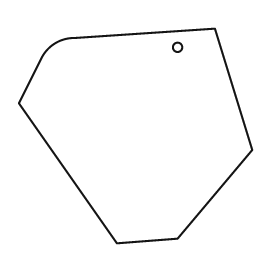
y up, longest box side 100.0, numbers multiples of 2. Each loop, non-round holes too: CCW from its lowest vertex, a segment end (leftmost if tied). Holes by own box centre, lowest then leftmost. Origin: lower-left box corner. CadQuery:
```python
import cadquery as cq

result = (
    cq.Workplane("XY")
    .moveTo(42.0, 0.0)
    .lineTo(68.0, 2.0)
    .lineTo(100.0, 40.0)
    .lineTo(84.0, 92.0)
    .lineTo(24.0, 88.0)
    .threePointArc((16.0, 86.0), (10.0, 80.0))
    .lineTo(0.0, 60.0)
    .close()
    .moveTo(68.0, 84.0)
    .circle(2.0)
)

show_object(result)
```